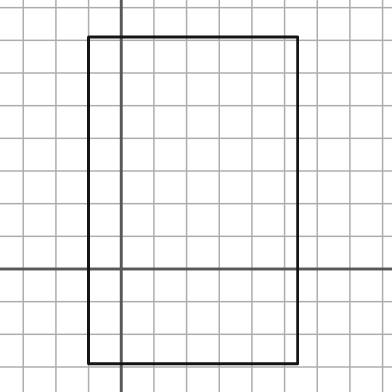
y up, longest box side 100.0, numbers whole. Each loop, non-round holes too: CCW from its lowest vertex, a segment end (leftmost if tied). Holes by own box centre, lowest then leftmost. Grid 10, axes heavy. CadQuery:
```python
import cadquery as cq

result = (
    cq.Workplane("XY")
    .moveTo(-10.0, -29.0)
    .lineTo(54.0, -29.0)
    .lineTo(54.0, 71.0)
    .lineTo(-10.0, 71.0)
    .close()
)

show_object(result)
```